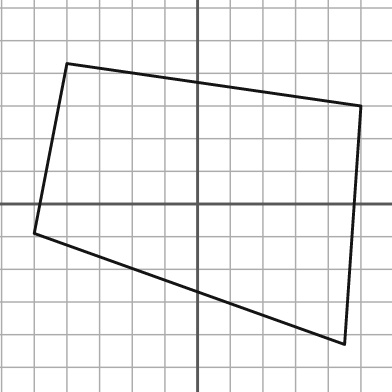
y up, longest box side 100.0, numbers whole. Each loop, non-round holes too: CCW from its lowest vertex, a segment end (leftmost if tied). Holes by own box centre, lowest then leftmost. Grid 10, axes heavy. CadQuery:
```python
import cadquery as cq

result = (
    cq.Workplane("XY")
    .moveTo(45.0, -43.0)
    .lineTo(50.0, 30.0)
    .lineTo(-40.0, 43.0)
    .lineTo(-50.0, -9.0)
    .close()
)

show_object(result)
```